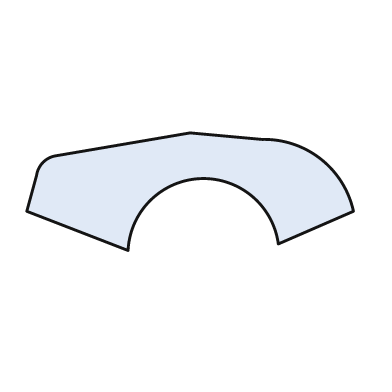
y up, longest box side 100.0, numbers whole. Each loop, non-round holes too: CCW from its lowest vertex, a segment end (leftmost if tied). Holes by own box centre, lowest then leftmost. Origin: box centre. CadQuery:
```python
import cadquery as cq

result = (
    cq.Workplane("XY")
    .moveTo(-19.0, -18.0)
    .threePointArc((3.0, 4.0), (27.0, -16.0))
    .lineTo(50.0, -6.0)
    .threePointArc((40.0, 10.0), (22.0, 16.0))
    .lineTo(0.0, 18.0)
    .lineTo(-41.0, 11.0)
    .threePointArc((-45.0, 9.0), (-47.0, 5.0))
    .lineTo(-50.0, -6.0)
    .close()
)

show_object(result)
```